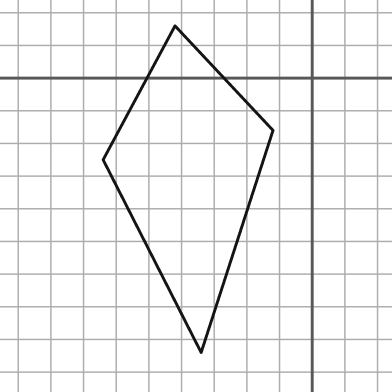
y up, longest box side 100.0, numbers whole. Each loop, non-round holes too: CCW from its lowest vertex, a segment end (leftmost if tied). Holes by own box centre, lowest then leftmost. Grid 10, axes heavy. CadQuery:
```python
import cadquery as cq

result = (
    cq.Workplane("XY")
    .moveTo(-34.0, -84.0)
    .lineTo(-12.0, -16.0)
    .lineTo(-42.0, 16.0)
    .lineTo(-64.0, -25.0)
    .close()
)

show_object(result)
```